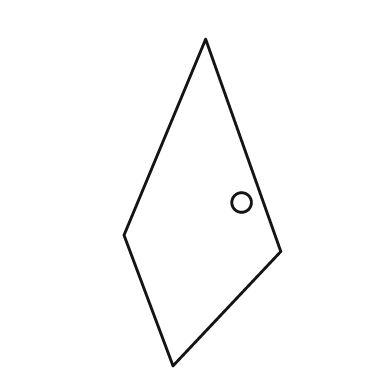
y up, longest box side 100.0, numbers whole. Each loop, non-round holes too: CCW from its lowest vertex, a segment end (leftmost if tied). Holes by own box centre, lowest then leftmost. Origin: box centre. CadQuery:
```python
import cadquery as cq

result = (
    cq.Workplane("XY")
    .moveTo(-9.0, -50.0)
    .lineTo(24.0, -15.0)
    .lineTo(1.0, 50.0)
    .lineTo(-24.0, -10.0)
    .close()
    .moveTo(12.0, 0.0)
    .circle(3.0)
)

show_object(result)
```